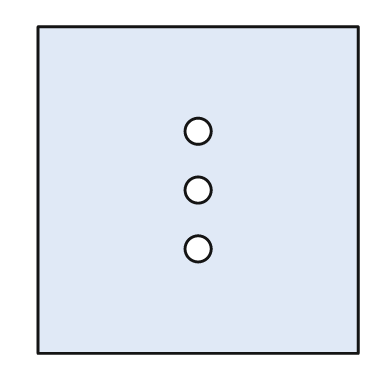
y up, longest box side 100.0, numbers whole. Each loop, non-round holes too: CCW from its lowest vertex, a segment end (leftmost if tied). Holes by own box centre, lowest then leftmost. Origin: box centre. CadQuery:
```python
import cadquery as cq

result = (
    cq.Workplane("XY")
    .moveTo(-49.0, -50.0)
    .lineTo(49.0, -50.0)
    .lineTo(49.0, 50.0)
    .lineTo(-49.0, 50.0)
    .close()
    .moveTo(0.0, -18.0)
    .circle(4.0)
    .moveTo(0.0, 0.0)
    .circle(4.0)
    .moveTo(0.0, 18.0)
    .circle(4.0)
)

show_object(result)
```